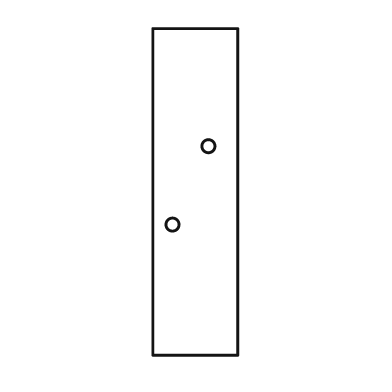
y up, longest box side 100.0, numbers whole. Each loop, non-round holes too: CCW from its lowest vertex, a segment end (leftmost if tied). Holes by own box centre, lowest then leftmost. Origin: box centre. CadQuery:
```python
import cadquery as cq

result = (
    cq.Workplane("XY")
    .moveTo(-13.0, -50.0)
    .lineTo(13.0, -50.0)
    .lineTo(13.0, 50.0)
    .lineTo(-13.0, 50.0)
    .close()
    .moveTo(-7.0, -10.0)
    .circle(2.0)
    .moveTo(4.0, 14.0)
    .circle(2.0)
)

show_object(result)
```